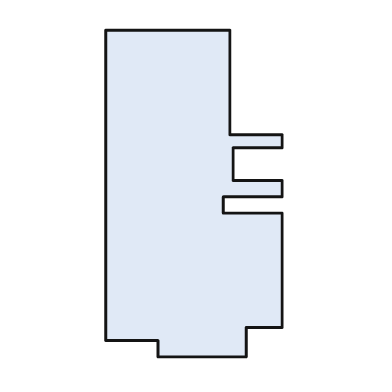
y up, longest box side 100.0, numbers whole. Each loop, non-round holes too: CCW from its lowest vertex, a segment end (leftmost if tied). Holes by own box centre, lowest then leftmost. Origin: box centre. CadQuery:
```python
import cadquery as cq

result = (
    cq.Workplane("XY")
    .moveTo(-11.0, -50.0)
    .lineTo(16.0, -50.0)
    .lineTo(16.0, -41.0)
    .lineTo(27.0, -41.0)
    .lineTo(27.0, -6.0)
    .lineTo(9.0, -6.0)
    .lineTo(9.0, -1.0)
    .lineTo(27.0, -1.0)
    .lineTo(27.0, 4.0)
    .lineTo(12.0, 4.0)
    .lineTo(12.0, 14.0)
    .lineTo(27.0, 14.0)
    .lineTo(27.0, 18.0)
    .lineTo(11.0, 18.0)
    .lineTo(11.0, 50.0)
    .lineTo(-27.0, 50.0)
    .lineTo(-27.0, -45.0)
    .lineTo(-11.0, -45.0)
    .close()
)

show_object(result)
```